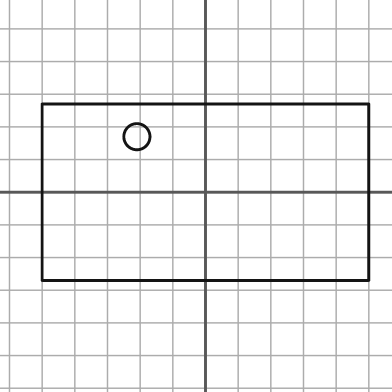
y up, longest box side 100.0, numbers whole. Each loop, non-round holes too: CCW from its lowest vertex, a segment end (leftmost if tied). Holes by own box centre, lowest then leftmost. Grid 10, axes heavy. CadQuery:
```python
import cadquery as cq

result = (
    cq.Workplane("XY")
    .moveTo(-50.0, -27.0)
    .lineTo(50.0, -27.0)
    .lineTo(50.0, 27.0)
    .lineTo(-50.0, 27.0)
    .close()
    .moveTo(-21.0, 17.0)
    .circle(4.0)
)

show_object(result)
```